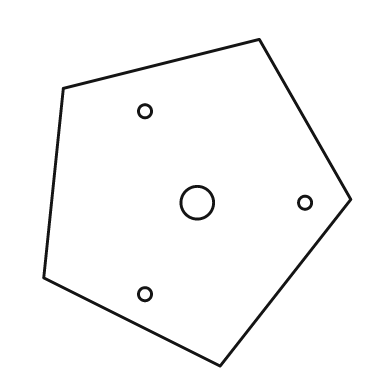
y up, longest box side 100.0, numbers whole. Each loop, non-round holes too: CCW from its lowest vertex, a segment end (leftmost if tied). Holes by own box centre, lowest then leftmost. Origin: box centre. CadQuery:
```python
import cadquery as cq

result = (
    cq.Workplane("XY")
    .moveTo(7.0, -50.0)
    .lineTo(47.0, 1.0)
    .lineTo(19.0, 50.0)
    .lineTo(-41.0, 35.0)
    .lineTo(-47.0, -23.0)
    .close()
    .moveTo(-16.0, -28.0)
    .circle(2.0)
    .moveTo(0.0, 0.0)
    .circle(5.0)
    .moveTo(33.0, 0.0)
    .circle(2.0)
    .moveTo(-16.0, 28.0)
    .circle(2.0)
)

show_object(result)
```